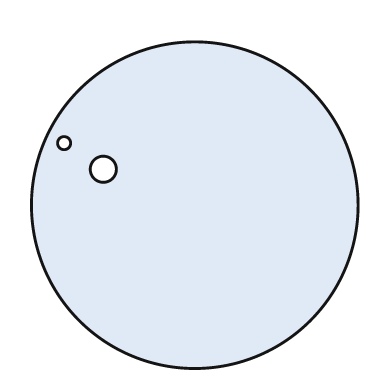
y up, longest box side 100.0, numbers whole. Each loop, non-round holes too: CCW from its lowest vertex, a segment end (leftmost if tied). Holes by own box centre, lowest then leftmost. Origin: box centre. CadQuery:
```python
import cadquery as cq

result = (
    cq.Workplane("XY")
    .moveTo(0.0, 0.0)
    .circle(50.0)
    .moveTo(-28.0, 11.0)
    .circle(4.0)
    .moveTo(-40.0, 19.0)
    .circle(2.0)
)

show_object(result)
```